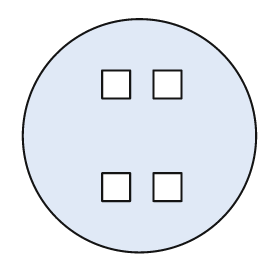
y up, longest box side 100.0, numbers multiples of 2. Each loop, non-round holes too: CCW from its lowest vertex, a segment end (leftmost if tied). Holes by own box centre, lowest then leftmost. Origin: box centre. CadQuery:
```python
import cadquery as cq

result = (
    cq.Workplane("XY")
    .moveTo(0.0, 0.0)
    .circle(50.0)
    .moveTo(-16.0, -28.0)
    .lineTo(-4.0, -28.0)
    .lineTo(-4.0, -16.0)
    .lineTo(-16.0, -16.0)
    .close()
    .moveTo(6.0, -28.0)
    .lineTo(18.0, -28.0)
    .lineTo(18.0, -16.0)
    .lineTo(6.0, -16.0)
    .close()
    .moveTo(-16.0, 16.0)
    .lineTo(-4.0, 16.0)
    .lineTo(-4.0, 28.0)
    .lineTo(-16.0, 28.0)
    .close()
    .moveTo(6.0, 16.0)
    .lineTo(18.0, 16.0)
    .lineTo(18.0, 28.0)
    .lineTo(6.0, 28.0)
    .close()
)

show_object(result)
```